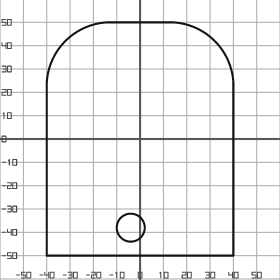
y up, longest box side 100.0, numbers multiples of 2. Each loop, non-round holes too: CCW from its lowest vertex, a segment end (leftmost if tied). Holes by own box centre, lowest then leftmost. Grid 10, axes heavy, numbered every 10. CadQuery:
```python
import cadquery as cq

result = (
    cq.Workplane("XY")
    .moveTo(-40.0, -50.0)
    .lineTo(40.0, -50.0)
    .lineTo(40.0, 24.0)
    .threePointArc((32.0, 42.0), (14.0, 50.0))
    .lineTo(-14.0, 50.0)
    .threePointArc((-32.0, 42.0), (-40.0, 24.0))
    .close()
    .moveTo(-4.0, -38.0)
    .circle(6.0)
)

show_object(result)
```